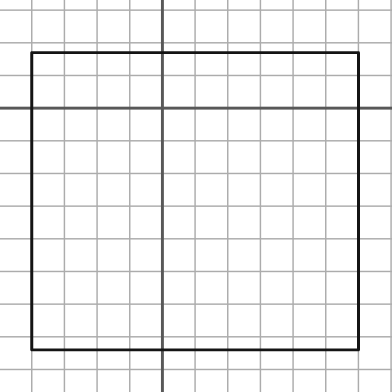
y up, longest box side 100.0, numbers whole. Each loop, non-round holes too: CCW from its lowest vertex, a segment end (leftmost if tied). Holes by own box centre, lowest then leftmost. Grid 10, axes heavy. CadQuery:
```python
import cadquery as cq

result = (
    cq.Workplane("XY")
    .moveTo(-40.0, -74.0)
    .lineTo(60.0, -74.0)
    .lineTo(60.0, 17.0)
    .lineTo(-40.0, 17.0)
    .close()
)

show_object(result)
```